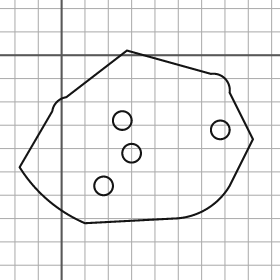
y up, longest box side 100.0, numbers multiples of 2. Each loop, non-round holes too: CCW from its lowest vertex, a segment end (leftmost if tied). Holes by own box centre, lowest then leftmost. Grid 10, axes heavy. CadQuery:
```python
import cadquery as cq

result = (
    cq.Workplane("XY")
    .moveTo(10.0, -72.0)
    .lineTo(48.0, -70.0)
    .threePointArc((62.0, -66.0), (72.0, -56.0))
    .lineTo(82.0, -36.0)
    .lineTo(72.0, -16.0)
    .threePointArc((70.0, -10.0), (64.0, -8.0))
    .lineTo(28.0, 2.0)
    .lineTo(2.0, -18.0)
    .threePointArc((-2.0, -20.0), (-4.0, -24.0))
    .lineTo(-18.0, -48.0)
    .threePointArc((-6.0, -62.0), (10.0, -72.0))
    .close()
    .moveTo(18.0, -56.0)
    .circle(4.0)
    .moveTo(30.0, -42.0)
    .circle(4.0)
    .moveTo(68.0, -32.0)
    .circle(4.0)
    .moveTo(26.0, -28.0)
    .circle(4.0)
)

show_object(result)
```